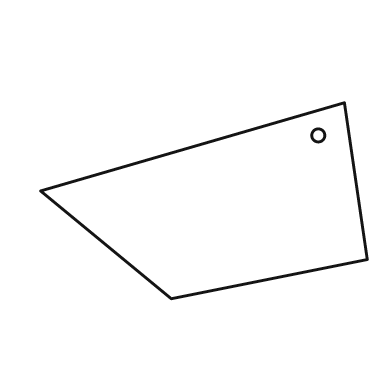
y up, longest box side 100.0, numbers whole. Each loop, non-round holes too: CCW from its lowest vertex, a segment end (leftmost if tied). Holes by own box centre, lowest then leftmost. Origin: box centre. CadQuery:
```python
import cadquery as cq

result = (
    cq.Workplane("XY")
    .moveTo(-10.0, -30.0)
    .lineTo(50.0, -18.0)
    .lineTo(43.0, 30.0)
    .lineTo(-50.0, 3.0)
    .close()
    .moveTo(35.0, 20.0)
    .circle(2.0)
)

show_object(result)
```